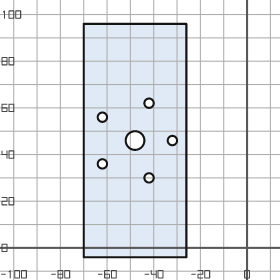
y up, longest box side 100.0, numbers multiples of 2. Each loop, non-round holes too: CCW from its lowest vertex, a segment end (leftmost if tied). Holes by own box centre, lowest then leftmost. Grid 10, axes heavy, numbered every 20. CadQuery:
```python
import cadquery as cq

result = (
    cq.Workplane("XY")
    .moveTo(-70.0, -4.0)
    .lineTo(-26.0, -4.0)
    .lineTo(-26.0, 96.0)
    .lineTo(-70.0, 96.0)
    .close()
    .moveTo(-42.0, 30.0)
    .circle(2.0)
    .moveTo(-62.0, 36.0)
    .circle(2.0)
    .moveTo(-48.0, 46.0)
    .circle(4.0)
    .moveTo(-32.0, 46.0)
    .circle(2.0)
    .moveTo(-62.0, 56.0)
    .circle(2.0)
    .moveTo(-42.0, 62.0)
    .circle(2.0)
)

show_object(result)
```